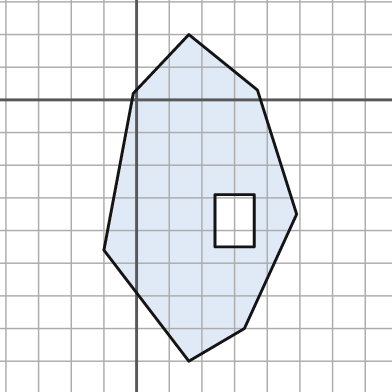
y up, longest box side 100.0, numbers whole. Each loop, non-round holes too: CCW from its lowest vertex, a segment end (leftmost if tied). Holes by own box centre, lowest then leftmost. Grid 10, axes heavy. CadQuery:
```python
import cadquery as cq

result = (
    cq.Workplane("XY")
    .moveTo(16.0, -80.0)
    .lineTo(33.0, -70.0)
    .lineTo(49.0, -35.0)
    .lineTo(37.0, 3.0)
    .lineTo(16.0, 20.0)
    .lineTo(-1.0, 2.0)
    .lineTo(-10.0, -46.0)
    .close()
    .moveTo(24.0, -45.0)
    .lineTo(36.0, -45.0)
    .lineTo(36.0, -29.0)
    .lineTo(24.0, -29.0)
    .close()
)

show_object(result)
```